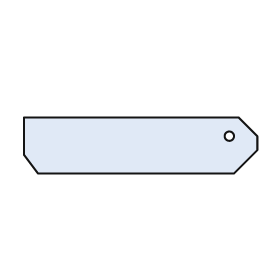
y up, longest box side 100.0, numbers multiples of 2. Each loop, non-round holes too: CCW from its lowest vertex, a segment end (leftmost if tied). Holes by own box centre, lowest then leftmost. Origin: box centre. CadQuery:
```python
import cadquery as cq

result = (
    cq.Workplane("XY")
    .moveTo(-44.0, -12.0)
    .lineTo(40.0, -12.0)
    .lineTo(50.0, -2.0)
    .lineTo(50.0, 4.0)
    .lineTo(42.0, 12.0)
    .lineTo(-50.0, 12.0)
    .lineTo(-50.0, -4.0)
    .close()
    .moveTo(38.0, 4.0)
    .circle(2.0)
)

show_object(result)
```